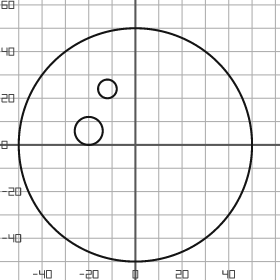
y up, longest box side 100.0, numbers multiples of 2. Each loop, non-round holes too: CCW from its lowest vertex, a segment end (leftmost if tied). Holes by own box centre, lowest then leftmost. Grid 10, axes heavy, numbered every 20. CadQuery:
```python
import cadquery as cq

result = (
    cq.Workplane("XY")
    .moveTo(0.0, 0.0)
    .circle(50.0)
    .moveTo(-20.0, 6.0)
    .circle(6.0)
    .moveTo(-12.0, 24.0)
    .circle(4.0)
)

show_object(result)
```